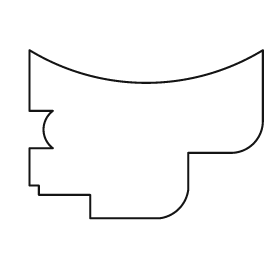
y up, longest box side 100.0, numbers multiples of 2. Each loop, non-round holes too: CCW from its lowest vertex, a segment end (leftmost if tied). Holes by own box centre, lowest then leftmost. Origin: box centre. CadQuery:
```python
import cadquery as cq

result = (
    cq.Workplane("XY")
    .moveTo(-24.0, -36.0)
    .lineTo(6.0, -36.0)
    .threePointArc((14.0, -32.0), (18.0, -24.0))
    .lineTo(18.0, -8.0)
    .lineTo(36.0, -8.0)
    .threePointArc((46.0, -4.0), (50.0, 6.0))
    .lineTo(50.0, 36.0)
    .threePointArc((0.0, 22.0), (-50.0, 36.0))
    .lineTo(-50.0, 10.0)
    .lineTo(-40.0, 10.0)
    .threePointArc((-44.0, 2.0), (-40.0, -6.0))
    .lineTo(-50.0, -6.0)
    .lineTo(-50.0, -22.0)
    .lineTo(-46.0, -22.0)
    .lineTo(-46.0, -26.0)
    .lineTo(-24.0, -26.0)
    .close()
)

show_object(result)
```